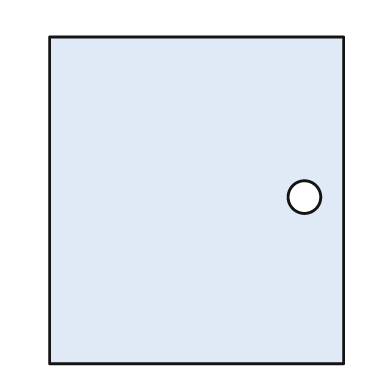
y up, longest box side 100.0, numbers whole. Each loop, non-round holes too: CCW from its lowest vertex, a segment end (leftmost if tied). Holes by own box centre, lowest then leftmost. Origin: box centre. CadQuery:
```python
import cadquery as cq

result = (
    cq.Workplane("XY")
    .moveTo(-45.0, -50.0)
    .lineTo(45.0, -50.0)
    .lineTo(45.0, 50.0)
    .lineTo(-45.0, 50.0)
    .close()
    .moveTo(33.0, 1.0)
    .circle(5.0)
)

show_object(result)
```